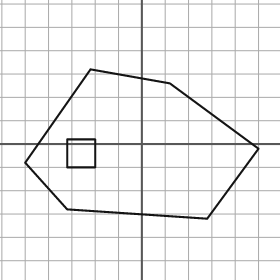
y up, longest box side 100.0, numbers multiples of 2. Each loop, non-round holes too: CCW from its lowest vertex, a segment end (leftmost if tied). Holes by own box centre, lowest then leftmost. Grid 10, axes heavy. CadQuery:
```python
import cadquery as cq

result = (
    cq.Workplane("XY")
    .moveTo(28.0, -32.0)
    .lineTo(50.0, -2.0)
    .lineTo(12.0, 26.0)
    .lineTo(-22.0, 32.0)
    .lineTo(-50.0, -8.0)
    .lineTo(-32.0, -28.0)
    .close()
    .moveTo(-32.0, -10.0)
    .lineTo(-20.0, -10.0)
    .lineTo(-20.0, 2.0)
    .lineTo(-32.0, 2.0)
    .close()
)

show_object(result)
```